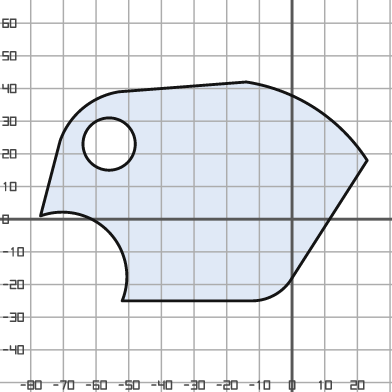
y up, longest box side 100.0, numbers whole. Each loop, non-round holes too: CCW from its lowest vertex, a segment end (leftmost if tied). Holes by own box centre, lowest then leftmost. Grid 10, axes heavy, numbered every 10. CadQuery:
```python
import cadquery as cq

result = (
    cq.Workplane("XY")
    .moveTo(-52.0, -25.0)
    .lineTo(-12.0, -25.0)
    .threePointArc((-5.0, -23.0), (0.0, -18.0))
    .lineTo(23.0, 18.0)
    .threePointArc((7.0, 34.0), (-14.0, 42.0))
    .lineTo(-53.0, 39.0)
    .threePointArc((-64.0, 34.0), (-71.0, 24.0))
    .lineTo(-77.0, 1.0)
    .threePointArc((-56.0, -4.0), (-52.0, -25.0))
    .close()
    .moveTo(-56.0, 23.0)
    .circle(8.0)
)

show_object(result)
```